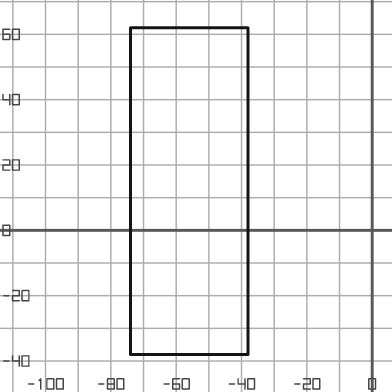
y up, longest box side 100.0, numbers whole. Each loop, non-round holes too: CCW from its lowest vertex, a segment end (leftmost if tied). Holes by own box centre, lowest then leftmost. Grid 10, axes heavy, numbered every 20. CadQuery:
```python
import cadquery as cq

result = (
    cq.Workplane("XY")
    .moveTo(-74.0, -38.0)
    .lineTo(-38.0, -38.0)
    .lineTo(-38.0, 62.0)
    .lineTo(-74.0, 62.0)
    .close()
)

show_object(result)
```